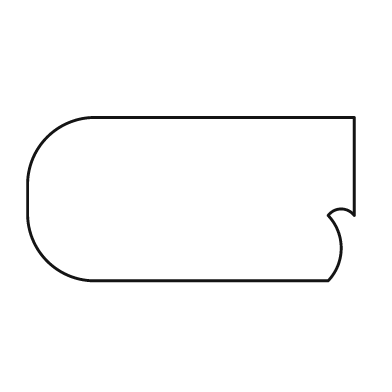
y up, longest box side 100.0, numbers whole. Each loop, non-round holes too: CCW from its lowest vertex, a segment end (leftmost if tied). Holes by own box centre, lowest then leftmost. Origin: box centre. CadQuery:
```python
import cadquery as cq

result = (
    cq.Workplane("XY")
    .moveTo(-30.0, -25.0)
    .lineTo(42.0, -25.0)
    .threePointArc((46.0, -15.0), (42.0, -5.0))
    .threePointArc((46.0, -3.0), (50.0, -5.0))
    .lineTo(50.0, 25.0)
    .lineTo(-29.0, 25.0)
    .threePointArc((-44.0, 19.0), (-50.0, 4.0))
    .lineTo(-50.0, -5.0)
    .threePointArc((-44.0, -19.0), (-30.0, -25.0))
    .close()
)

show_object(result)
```